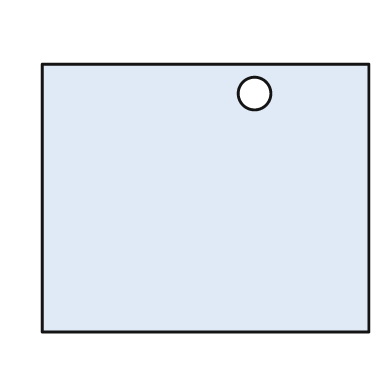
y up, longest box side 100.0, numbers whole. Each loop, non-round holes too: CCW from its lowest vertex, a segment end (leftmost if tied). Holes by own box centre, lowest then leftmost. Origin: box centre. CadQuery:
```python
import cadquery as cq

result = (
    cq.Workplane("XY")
    .moveTo(-50.0, -41.0)
    .lineTo(50.0, -41.0)
    .lineTo(50.0, 41.0)
    .lineTo(-50.0, 41.0)
    .close()
    .moveTo(15.0, 32.0)
    .circle(5.0)
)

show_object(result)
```